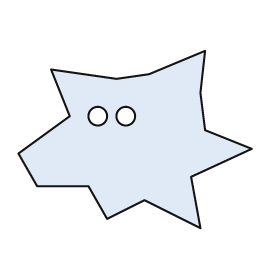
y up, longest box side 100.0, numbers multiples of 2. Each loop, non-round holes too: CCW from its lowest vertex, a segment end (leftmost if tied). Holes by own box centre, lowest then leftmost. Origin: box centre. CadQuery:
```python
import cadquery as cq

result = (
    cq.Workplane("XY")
    .moveTo(28.0, -38.0)
    .lineTo(24.0, -16.0)
    .lineTo(50.0, -4.0)
    .lineTo(30.0, 4.0)
    .lineTo(28.0, 20.0)
    .lineTo(30.0, 38.0)
    .lineTo(6.0, 28.0)
    .lineTo(-8.0, 26.0)
    .lineTo(-36.0, 30.0)
    .lineTo(-28.0, 10.0)
    .lineTo(-50.0, -6.0)
    .lineTo(-42.0, -20.0)
    .lineTo(-20.0, -20.0)
    .lineTo(-12.0, -34.0)
    .lineTo(4.0, -26.0)
    .close()
    .moveTo(-16.0, 10.0)
    .circle(4.0)
    .moveTo(-4.0, 10.0)
    .circle(4.0)
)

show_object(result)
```